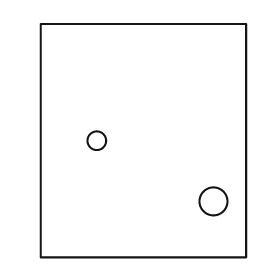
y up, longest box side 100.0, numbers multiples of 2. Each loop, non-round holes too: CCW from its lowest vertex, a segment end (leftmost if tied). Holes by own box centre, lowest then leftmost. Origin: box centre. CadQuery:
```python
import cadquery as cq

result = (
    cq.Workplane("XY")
    .moveTo(-44.0, -50.0)
    .lineTo(44.0, -50.0)
    .lineTo(44.0, 50.0)
    .lineTo(-44.0, 50.0)
    .close()
    .moveTo(30.0, -26.0)
    .circle(6.0)
    .moveTo(-20.0, 0.0)
    .circle(4.0)
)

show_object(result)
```